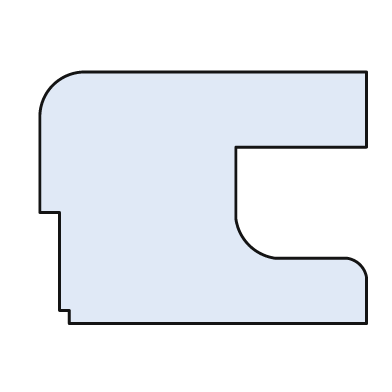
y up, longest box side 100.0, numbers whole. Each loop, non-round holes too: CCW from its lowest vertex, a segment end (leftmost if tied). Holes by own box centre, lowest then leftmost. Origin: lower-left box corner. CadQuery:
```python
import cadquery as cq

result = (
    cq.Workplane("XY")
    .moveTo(9.0, 0.0)
    .lineTo(100.0, 0.0)
    .lineTo(100.0, 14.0)
    .threePointArc((98.0, 18.0), (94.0, 20.0))
    .lineTo(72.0, 20.0)
    .threePointArc((64.0, 24.0), (60.0, 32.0))
    .lineTo(60.0, 54.0)
    .lineTo(100.0, 54.0)
    .lineTo(100.0, 77.0)
    .lineTo(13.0, 77.0)
    .threePointArc((4.0, 73.0), (0.0, 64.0))
    .lineTo(0.0, 34.0)
    .lineTo(6.0, 34.0)
    .lineTo(6.0, 4.0)
    .lineTo(9.0, 4.0)
    .close()
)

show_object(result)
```